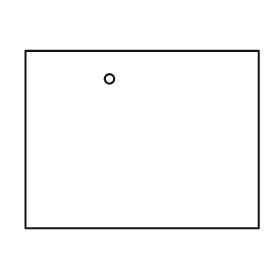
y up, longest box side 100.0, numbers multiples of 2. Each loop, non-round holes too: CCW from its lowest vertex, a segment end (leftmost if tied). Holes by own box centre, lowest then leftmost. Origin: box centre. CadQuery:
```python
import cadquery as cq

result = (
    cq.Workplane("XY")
    .moveTo(-50.0, -38.0)
    .lineTo(50.0, -38.0)
    .lineTo(50.0, 38.0)
    .lineTo(-50.0, 38.0)
    .close()
    .moveTo(-14.0, 26.0)
    .circle(2.0)
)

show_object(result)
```